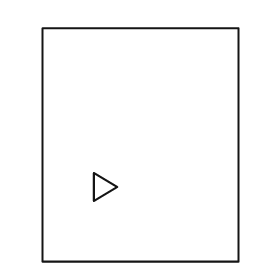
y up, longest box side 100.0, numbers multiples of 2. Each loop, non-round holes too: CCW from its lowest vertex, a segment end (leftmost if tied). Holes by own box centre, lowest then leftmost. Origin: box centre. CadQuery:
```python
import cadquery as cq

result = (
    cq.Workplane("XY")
    .moveTo(-42.0, -50.0)
    .lineTo(42.0, -50.0)
    .lineTo(42.0, 50.0)
    .lineTo(-42.0, 50.0)
    .close()
    .moveTo(-20.0, -24.0)
    .lineTo(-10.0, -18.0)
    .lineTo(-20.0, -12.0)
    .close()
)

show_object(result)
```